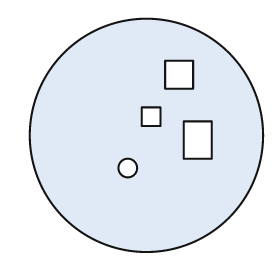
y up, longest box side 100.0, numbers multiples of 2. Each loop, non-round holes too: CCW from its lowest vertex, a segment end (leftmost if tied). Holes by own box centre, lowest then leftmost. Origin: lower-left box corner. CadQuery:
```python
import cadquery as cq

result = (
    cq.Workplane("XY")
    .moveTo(50.0, 50.0)
    .circle(50.0)
    .moveTo(42.0, 36.0)
    .circle(4.0)
    .moveTo(66.0, 40.0)
    .lineTo(78.0, 40.0)
    .lineTo(78.0, 56.0)
    .lineTo(66.0, 56.0)
    .close()
    .moveTo(48.0, 54.0)
    .lineTo(56.0, 54.0)
    .lineTo(56.0, 62.0)
    .lineTo(48.0, 62.0)
    .close()
    .moveTo(58.0, 70.0)
    .lineTo(70.0, 70.0)
    .lineTo(70.0, 82.0)
    .lineTo(58.0, 82.0)
    .close()
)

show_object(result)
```